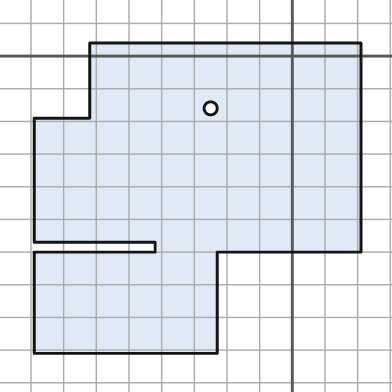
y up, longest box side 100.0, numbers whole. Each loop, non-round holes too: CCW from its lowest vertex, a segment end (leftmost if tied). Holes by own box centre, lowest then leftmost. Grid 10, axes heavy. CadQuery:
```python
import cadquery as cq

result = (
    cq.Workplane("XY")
    .moveTo(-79.0, -91.0)
    .lineTo(-23.0, -91.0)
    .lineTo(-23.0, -60.0)
    .lineTo(21.0, -60.0)
    .lineTo(21.0, 4.0)
    .lineTo(-62.0, 4.0)
    .lineTo(-62.0, -19.0)
    .lineTo(-79.0, -19.0)
    .lineTo(-79.0, -57.0)
    .lineTo(-42.0, -57.0)
    .lineTo(-42.0, -60.0)
    .lineTo(-79.0, -60.0)
    .close()
    .moveTo(-25.0, -16.0)
    .circle(2.0)
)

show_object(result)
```